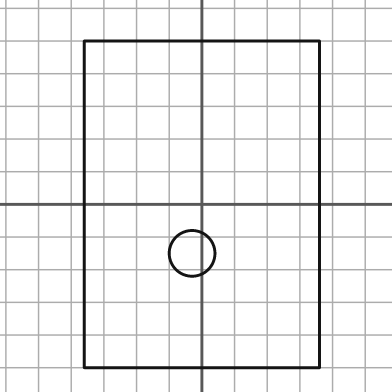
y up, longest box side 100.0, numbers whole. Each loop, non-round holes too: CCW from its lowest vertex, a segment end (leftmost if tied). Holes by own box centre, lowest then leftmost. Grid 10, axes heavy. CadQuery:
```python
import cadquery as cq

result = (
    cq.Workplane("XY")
    .moveTo(-36.0, -50.0)
    .lineTo(36.0, -50.0)
    .lineTo(36.0, 50.0)
    .lineTo(-36.0, 50.0)
    .close()
    .moveTo(-3.0, -15.0)
    .circle(7.0)
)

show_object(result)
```